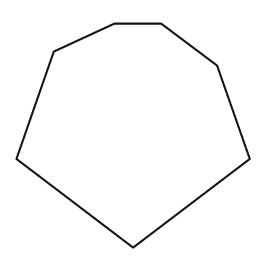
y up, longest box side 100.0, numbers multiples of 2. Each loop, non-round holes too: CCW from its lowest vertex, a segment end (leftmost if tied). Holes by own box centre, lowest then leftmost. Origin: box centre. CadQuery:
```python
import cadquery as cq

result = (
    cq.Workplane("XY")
    .moveTo(0.0, -48.0)
    .lineTo(50.0, -10.0)
    .lineTo(36.0, 30.0)
    .lineTo(12.0, 48.0)
    .lineTo(-8.0, 48.0)
    .lineTo(-34.0, 36.0)
    .lineTo(-50.0, -10.0)
    .close()
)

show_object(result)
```